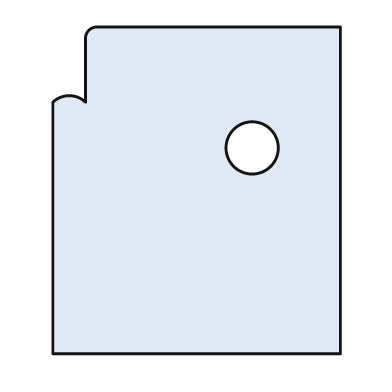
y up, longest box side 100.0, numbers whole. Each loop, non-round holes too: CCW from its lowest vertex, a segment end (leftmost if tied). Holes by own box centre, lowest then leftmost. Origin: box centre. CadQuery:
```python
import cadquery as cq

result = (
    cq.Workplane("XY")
    .moveTo(-44.0, -50.0)
    .lineTo(44.0, -50.0)
    .lineTo(44.0, 50.0)
    .lineTo(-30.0, 50.0)
    .threePointArc((-33.0, 49.0), (-34.0, 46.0))
    .lineTo(-34.0, 27.0)
    .threePointArc((-39.0, 29.0), (-44.0, 27.0))
    .close()
    .moveTo(17.0, 13.0)
    .circle(8.0)
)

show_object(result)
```